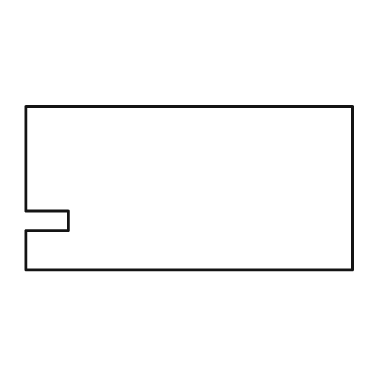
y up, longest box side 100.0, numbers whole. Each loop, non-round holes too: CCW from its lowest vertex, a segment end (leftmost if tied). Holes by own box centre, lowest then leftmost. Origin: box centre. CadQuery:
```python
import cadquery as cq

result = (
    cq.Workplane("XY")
    .moveTo(-50.0, -25.0)
    .lineTo(50.0, -25.0)
    .lineTo(50.0, 25.0)
    .lineTo(-50.0, 25.0)
    .lineTo(-50.0, -7.0)
    .lineTo(-37.0, -7.0)
    .lineTo(-37.0, -13.0)
    .lineTo(-50.0, -13.0)
    .close()
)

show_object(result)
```